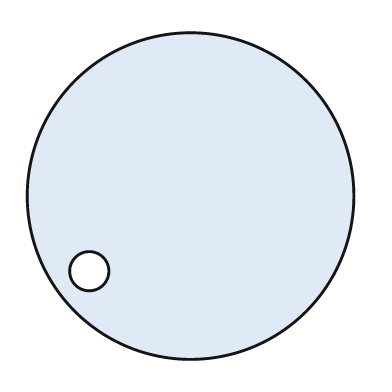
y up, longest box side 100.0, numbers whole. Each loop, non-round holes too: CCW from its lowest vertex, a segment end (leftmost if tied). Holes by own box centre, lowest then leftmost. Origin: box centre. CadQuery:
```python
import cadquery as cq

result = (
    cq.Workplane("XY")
    .moveTo(0.0, 0.0)
    .circle(50.0)
    .moveTo(-31.0, -23.0)
    .circle(6.0)
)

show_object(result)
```